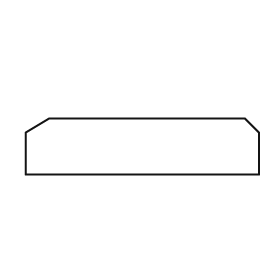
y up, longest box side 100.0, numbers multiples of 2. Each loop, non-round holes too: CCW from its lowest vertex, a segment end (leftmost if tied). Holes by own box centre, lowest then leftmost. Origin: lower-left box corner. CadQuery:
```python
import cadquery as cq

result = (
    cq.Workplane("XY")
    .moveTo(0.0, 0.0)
    .lineTo(100.0, 0.0)
    .lineTo(100.0, 18.0)
    .lineTo(94.0, 24.0)
    .lineTo(10.0, 24.0)
    .lineTo(0.0, 18.0)
    .close()
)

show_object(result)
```